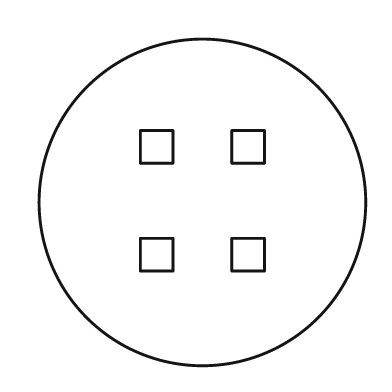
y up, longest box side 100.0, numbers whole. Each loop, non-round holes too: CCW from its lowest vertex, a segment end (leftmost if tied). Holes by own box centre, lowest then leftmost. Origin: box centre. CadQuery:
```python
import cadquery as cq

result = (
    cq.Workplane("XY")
    .moveTo(0.0, 0.0)
    .circle(50.0)
    .moveTo(-19.0, -21.0)
    .lineTo(-9.0, -21.0)
    .lineTo(-9.0, -11.0)
    .lineTo(-19.0, -11.0)
    .close()
    .moveTo(9.0, -21.0)
    .lineTo(19.0, -21.0)
    .lineTo(19.0, -11.0)
    .lineTo(9.0, -11.0)
    .close()
    .moveTo(-19.0, 12.0)
    .lineTo(-9.0, 12.0)
    .lineTo(-9.0, 22.0)
    .lineTo(-19.0, 22.0)
    .close()
    .moveTo(9.0, 12.0)
    .lineTo(19.0, 12.0)
    .lineTo(19.0, 22.0)
    .lineTo(9.0, 22.0)
    .close()
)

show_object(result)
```